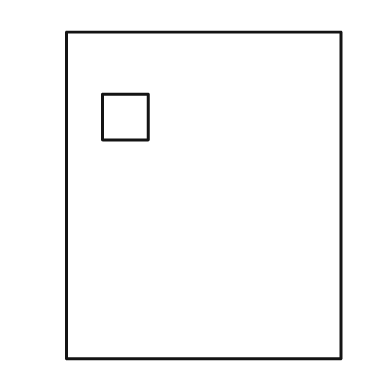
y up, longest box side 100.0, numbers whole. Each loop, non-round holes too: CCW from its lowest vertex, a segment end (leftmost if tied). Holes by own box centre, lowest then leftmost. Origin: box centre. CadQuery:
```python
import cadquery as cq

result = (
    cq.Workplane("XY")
    .moveTo(-42.0, -50.0)
    .lineTo(42.0, -50.0)
    .lineTo(42.0, 50.0)
    .lineTo(-42.0, 50.0)
    .close()
    .moveTo(-31.0, 17.0)
    .lineTo(-17.0, 17.0)
    .lineTo(-17.0, 31.0)
    .lineTo(-31.0, 31.0)
    .close()
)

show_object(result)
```